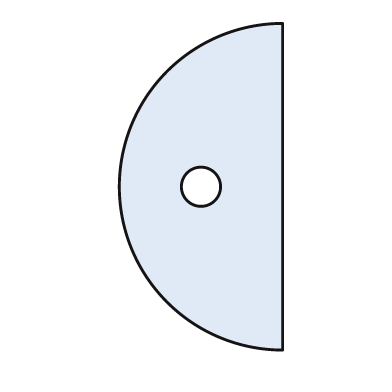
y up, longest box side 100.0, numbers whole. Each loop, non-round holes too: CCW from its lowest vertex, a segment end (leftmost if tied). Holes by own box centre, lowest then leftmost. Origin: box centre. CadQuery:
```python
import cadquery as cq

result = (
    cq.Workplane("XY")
    .moveTo(25.0, -50.0)
    .lineTo(25.0, 50.0)
    .threePointArc((-25.0, 0.0), (25.0, -50.0))
    .close()
    .moveTo(0.0, 0.0)
    .circle(6.0)
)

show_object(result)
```